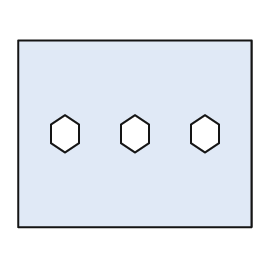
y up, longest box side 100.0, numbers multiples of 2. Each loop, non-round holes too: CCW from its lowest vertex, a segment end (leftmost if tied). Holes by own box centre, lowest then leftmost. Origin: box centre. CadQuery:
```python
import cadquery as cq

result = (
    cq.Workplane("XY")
    .moveTo(-50.0, -40.0)
    .lineTo(50.0, -40.0)
    .lineTo(50.0, 40.0)
    .lineTo(-50.0, 40.0)
    .close()
    .moveTo(-30.0, -8.0)
    .lineTo(-24.0, -4.0)
    .lineTo(-24.0, 4.0)
    .lineTo(-30.0, 8.0)
    .lineTo(-36.0, 4.0)
    .lineTo(-36.0, -4.0)
    .close()
    .moveTo(0.0, -8.0)
    .lineTo(6.0, -4.0)
    .lineTo(6.0, 4.0)
    .lineTo(0.0, 8.0)
    .lineTo(-6.0, 4.0)
    .lineTo(-6.0, -4.0)
    .close()
    .moveTo(30.0, -8.0)
    .lineTo(36.0, -4.0)
    .lineTo(36.0, 4.0)
    .lineTo(30.0, 8.0)
    .lineTo(24.0, 4.0)
    .lineTo(24.0, -4.0)
    .close()
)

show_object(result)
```